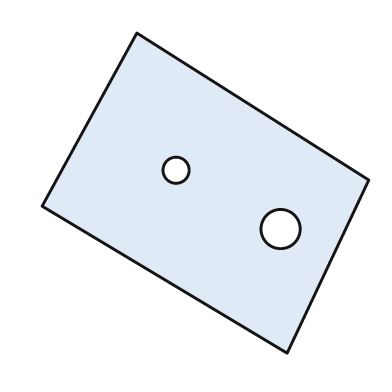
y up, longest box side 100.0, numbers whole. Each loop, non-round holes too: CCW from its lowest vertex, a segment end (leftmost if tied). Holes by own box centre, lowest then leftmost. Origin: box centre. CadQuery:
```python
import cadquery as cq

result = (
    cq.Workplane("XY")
    .moveTo(25.0, -49.0)
    .lineTo(50.0, 4.0)
    .lineTo(-21.0, 49.0)
    .lineTo(-50.0, -4.0)
    .close()
    .moveTo(23.0, -11.0)
    .circle(6.0)
    .moveTo(-9.0, 7.0)
    .circle(4.0)
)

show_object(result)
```